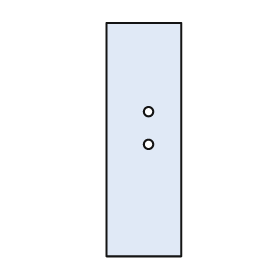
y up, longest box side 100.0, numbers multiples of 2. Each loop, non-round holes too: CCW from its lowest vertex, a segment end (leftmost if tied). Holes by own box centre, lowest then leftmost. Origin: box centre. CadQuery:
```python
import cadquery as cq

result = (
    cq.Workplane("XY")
    .moveTo(-16.0, -50.0)
    .lineTo(16.0, -50.0)
    .lineTo(16.0, 50.0)
    .lineTo(-16.0, 50.0)
    .close()
    .moveTo(2.0, -2.0)
    .circle(2.0)
    .moveTo(2.0, 12.0)
    .circle(2.0)
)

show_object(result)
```